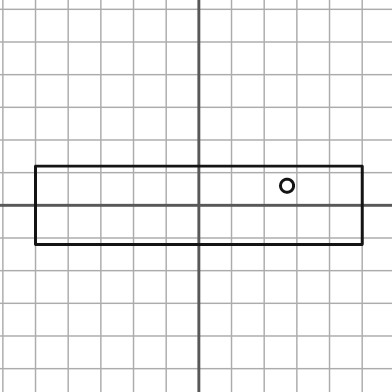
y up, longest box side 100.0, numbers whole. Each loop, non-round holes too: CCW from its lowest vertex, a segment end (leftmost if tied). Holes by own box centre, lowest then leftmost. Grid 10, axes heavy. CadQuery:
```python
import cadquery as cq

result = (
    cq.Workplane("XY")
    .moveTo(-50.0, -12.0)
    .lineTo(50.0, -12.0)
    .lineTo(50.0, 12.0)
    .lineTo(-50.0, 12.0)
    .close()
    .moveTo(27.0, 6.0)
    .circle(2.0)
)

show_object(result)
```